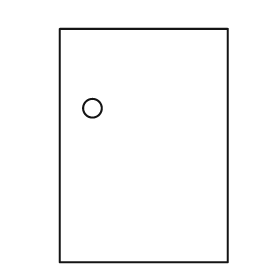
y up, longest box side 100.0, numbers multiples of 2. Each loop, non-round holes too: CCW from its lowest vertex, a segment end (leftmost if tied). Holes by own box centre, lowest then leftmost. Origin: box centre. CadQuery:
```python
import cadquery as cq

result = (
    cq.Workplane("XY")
    .moveTo(-36.0, -50.0)
    .lineTo(36.0, -50.0)
    .lineTo(36.0, 50.0)
    .lineTo(-36.0, 50.0)
    .close()
    .moveTo(-22.0, 16.0)
    .circle(4.0)
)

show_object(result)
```